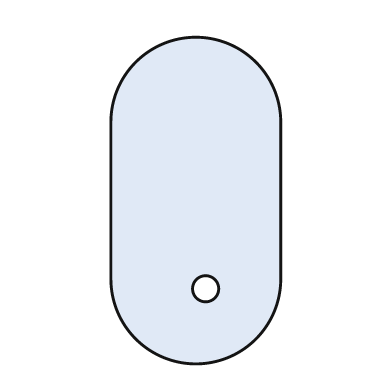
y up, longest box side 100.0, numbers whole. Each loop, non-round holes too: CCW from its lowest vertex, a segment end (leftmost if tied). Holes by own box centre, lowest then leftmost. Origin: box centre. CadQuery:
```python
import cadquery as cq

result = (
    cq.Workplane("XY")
    .moveTo(-26.0, -24.0)
    .threePointArc((0.0, -50.0), (26.0, -24.0))
    .lineTo(26.0, 24.0)
    .threePointArc((0.0, 50.0), (-26.0, 24.0))
    .close()
    .moveTo(3.0, -27.0)
    .circle(4.0)
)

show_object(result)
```